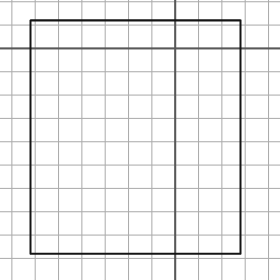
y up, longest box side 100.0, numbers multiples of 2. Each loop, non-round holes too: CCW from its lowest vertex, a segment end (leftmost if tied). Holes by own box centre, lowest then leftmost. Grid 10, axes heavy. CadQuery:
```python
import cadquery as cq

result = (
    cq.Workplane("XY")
    .moveTo(-62.0, -88.0)
    .lineTo(28.0, -88.0)
    .lineTo(28.0, 12.0)
    .lineTo(-62.0, 12.0)
    .close()
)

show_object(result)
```